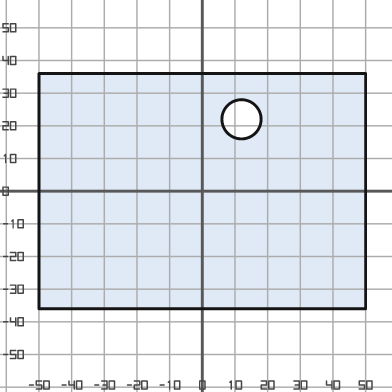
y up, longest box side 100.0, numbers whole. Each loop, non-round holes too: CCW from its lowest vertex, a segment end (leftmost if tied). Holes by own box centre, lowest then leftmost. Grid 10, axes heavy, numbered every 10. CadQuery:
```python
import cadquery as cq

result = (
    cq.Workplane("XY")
    .moveTo(-50.0, -36.0)
    .lineTo(50.0, -36.0)
    .lineTo(50.0, 36.0)
    .lineTo(-50.0, 36.0)
    .close()
    .moveTo(12.0, 22.0)
    .circle(6.0)
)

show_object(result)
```